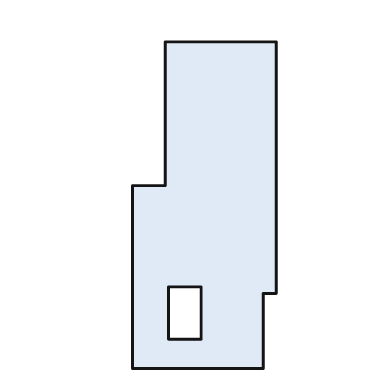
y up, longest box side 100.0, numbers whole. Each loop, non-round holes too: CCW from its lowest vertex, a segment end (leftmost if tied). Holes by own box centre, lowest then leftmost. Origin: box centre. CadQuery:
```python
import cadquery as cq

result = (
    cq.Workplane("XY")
    .moveTo(-22.0, -50.0)
    .lineTo(18.0, -50.0)
    .lineTo(18.0, -27.0)
    .lineTo(22.0, -27.0)
    .lineTo(22.0, 50.0)
    .lineTo(-12.0, 50.0)
    .lineTo(-12.0, 6.0)
    .lineTo(-22.0, 6.0)
    .close()
    .moveTo(-11.0, -41.0)
    .lineTo(-1.0, -41.0)
    .lineTo(-1.0, -25.0)
    .lineTo(-11.0, -25.0)
    .close()
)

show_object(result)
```